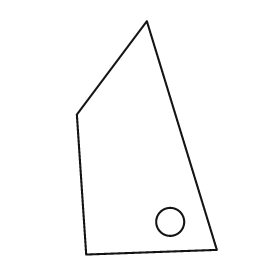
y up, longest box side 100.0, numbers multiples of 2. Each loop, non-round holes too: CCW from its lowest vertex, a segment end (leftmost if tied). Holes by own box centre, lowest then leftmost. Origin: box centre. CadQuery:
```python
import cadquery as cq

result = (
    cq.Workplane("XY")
    .moveTo(-26.0, -50.0)
    .lineTo(30.0, -48.0)
    .lineTo(0.0, 50.0)
    .lineTo(-30.0, 10.0)
    .close()
    .moveTo(10.0, -36.0)
    .circle(6.0)
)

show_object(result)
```